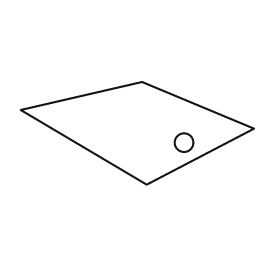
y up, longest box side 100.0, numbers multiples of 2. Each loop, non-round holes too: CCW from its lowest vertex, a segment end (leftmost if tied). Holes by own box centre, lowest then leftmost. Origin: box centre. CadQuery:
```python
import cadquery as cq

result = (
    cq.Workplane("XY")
    .moveTo(4.0, -22.0)
    .lineTo(50.0, 2.0)
    .lineTo(2.0, 22.0)
    .lineTo(-50.0, 10.0)
    .close()
    .moveTo(20.0, -4.0)
    .circle(4.0)
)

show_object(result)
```